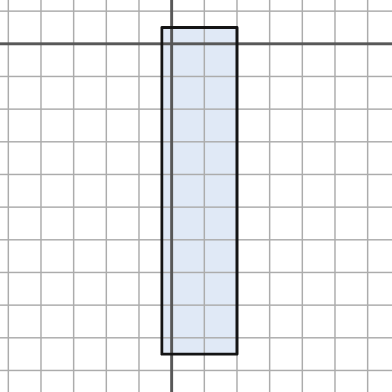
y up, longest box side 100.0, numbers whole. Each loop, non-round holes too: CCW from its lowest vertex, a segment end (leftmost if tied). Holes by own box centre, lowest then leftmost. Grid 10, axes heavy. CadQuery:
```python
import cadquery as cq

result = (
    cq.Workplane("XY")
    .moveTo(-3.0, -95.0)
    .lineTo(20.0, -95.0)
    .lineTo(20.0, 5.0)
    .lineTo(-3.0, 5.0)
    .close()
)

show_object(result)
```